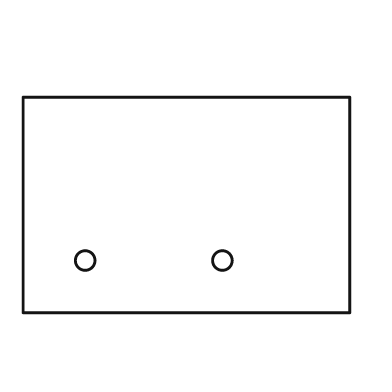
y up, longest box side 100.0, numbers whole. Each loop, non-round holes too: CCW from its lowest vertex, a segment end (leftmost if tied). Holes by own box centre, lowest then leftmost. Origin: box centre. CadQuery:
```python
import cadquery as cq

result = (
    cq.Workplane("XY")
    .moveTo(-50.0, -33.0)
    .lineTo(50.0, -33.0)
    .lineTo(50.0, 33.0)
    .lineTo(-50.0, 33.0)
    .close()
    .moveTo(-31.0, -17.0)
    .circle(3.0)
    .moveTo(11.0, -17.0)
    .circle(3.0)
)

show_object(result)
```